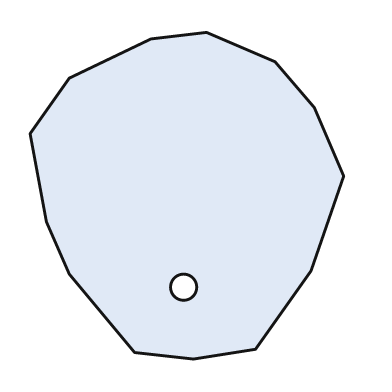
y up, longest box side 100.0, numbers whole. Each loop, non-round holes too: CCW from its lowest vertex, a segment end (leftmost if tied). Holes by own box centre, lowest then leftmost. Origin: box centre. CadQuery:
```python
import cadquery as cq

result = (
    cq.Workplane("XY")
    .moveTo(2.0, -50.0)
    .lineTo(21.0, -47.0)
    .lineTo(38.0, -23.0)
    .lineTo(48.0, 6.0)
    .lineTo(39.0, 27.0)
    .lineTo(27.0, 41.0)
    .lineTo(6.0, 50.0)
    .lineTo(-11.0, 48.0)
    .lineTo(-36.0, 36.0)
    .lineTo(-48.0, 19.0)
    .lineTo(-43.0, -8.0)
    .lineTo(-36.0, -24.0)
    .lineTo(-16.0, -48.0)
    .close()
    .moveTo(-1.0, -28.0)
    .circle(4.0)
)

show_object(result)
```